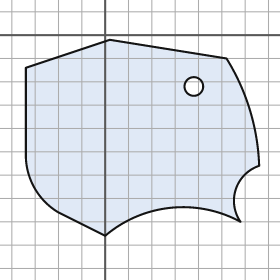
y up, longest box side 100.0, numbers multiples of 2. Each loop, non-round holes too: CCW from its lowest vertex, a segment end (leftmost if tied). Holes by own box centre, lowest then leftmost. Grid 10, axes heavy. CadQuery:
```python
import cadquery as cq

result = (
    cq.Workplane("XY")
    .moveTo(0.0, -86.0)
    .threePointArc((28.0, -74.0), (58.0, -80.0))
    .threePointArc((56.0, -66.0), (66.0, -56.0))
    .threePointArc((62.0, -32.0), (52.0, -10.0))
    .lineTo(2.0, -2.0)
    .lineTo(-34.0, -14.0)
    .lineTo(-34.0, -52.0)
    .threePointArc((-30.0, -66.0), (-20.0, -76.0))
    .close()
    .moveTo(38.0, -22.0)
    .circle(4.0)
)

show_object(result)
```